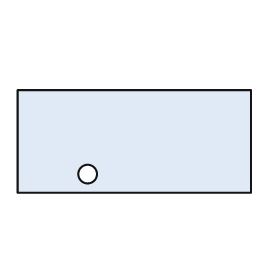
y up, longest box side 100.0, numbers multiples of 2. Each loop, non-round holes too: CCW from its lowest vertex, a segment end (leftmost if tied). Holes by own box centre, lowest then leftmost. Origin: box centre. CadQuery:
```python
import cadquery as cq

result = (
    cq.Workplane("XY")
    .moveTo(-50.0, -22.0)
    .lineTo(50.0, -22.0)
    .lineTo(50.0, 22.0)
    .lineTo(-50.0, 22.0)
    .close()
    .moveTo(-20.0, -14.0)
    .circle(4.0)
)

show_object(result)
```